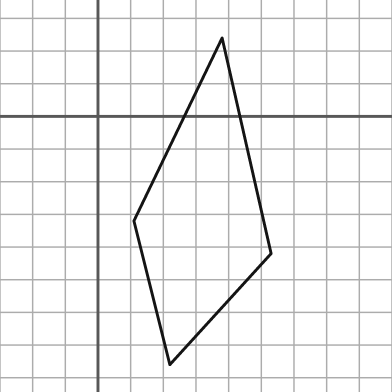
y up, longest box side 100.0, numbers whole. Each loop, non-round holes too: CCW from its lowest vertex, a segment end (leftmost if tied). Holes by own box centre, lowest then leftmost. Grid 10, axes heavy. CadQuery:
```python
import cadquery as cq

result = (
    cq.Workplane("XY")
    .moveTo(22.0, -76.0)
    .lineTo(53.0, -42.0)
    .lineTo(38.0, 24.0)
    .lineTo(11.0, -32.0)
    .close()
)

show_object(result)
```